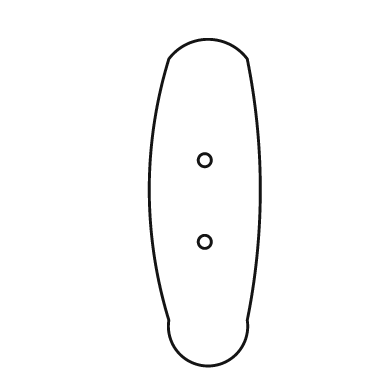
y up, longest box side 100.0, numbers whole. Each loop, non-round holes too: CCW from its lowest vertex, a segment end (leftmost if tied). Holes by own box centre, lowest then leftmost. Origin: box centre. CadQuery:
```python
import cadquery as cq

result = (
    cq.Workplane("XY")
    .moveTo(-11.0, -36.0)
    .threePointArc((1.0, -50.0), (13.0, -36.0))
    .threePointArc((17.0, 4.0), (13.0, 44.0))
    .threePointArc((1.0, 50.0), (-11.0, 44.0))
    .threePointArc((-17.0, 4.0), (-11.0, -36.0))
    .close()
    .moveTo(0.0, -12.0)
    .circle(2.0)
    .moveTo(0.0, 13.0)
    .circle(2.0)
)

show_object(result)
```